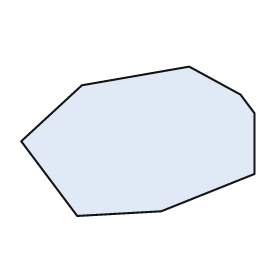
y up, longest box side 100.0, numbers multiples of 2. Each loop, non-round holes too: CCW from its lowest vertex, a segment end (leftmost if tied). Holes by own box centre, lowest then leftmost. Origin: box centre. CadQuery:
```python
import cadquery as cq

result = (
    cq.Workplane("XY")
    .moveTo(-26.0, -32.0)
    .lineTo(10.0, -30.0)
    .lineTo(50.0, -14.0)
    .lineTo(50.0, 12.0)
    .lineTo(44.0, 20.0)
    .lineTo(22.0, 32.0)
    .lineTo(-24.0, 24.0)
    .lineTo(-50.0, 0.0)
    .close()
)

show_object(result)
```